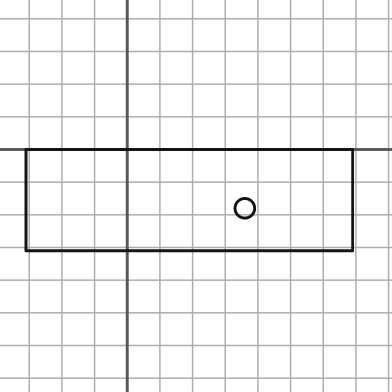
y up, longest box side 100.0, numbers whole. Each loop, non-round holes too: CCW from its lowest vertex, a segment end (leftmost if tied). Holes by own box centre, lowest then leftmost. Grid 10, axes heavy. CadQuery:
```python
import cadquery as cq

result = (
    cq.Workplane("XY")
    .moveTo(-31.0, -31.0)
    .lineTo(69.0, -31.0)
    .lineTo(69.0, 0.0)
    .lineTo(-31.0, 0.0)
    .close()
    .moveTo(36.0, -18.0)
    .circle(3.0)
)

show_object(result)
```